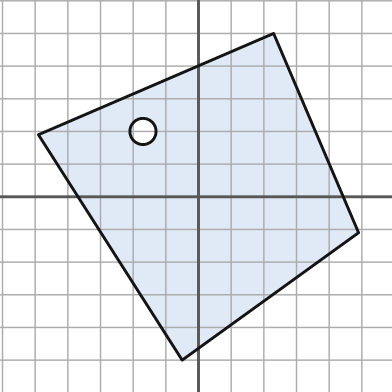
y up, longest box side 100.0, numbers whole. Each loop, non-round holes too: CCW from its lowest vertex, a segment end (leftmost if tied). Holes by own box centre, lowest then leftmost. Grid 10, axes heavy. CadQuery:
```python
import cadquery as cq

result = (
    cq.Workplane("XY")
    .moveTo(-5.0, -50.0)
    .lineTo(49.0, -11.0)
    .lineTo(23.0, 50.0)
    .lineTo(-49.0, 19.0)
    .close()
    .moveTo(-17.0, 20.0)
    .circle(4.0)
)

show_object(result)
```